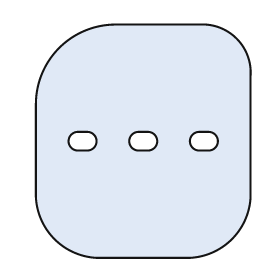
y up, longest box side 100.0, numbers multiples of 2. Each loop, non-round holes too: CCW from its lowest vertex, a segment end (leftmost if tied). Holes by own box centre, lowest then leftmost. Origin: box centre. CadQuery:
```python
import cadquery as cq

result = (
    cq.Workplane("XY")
    .moveTo(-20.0, -50.0)
    .lineTo(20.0, -50.0)
    .threePointArc((38.0, -42.0), (46.0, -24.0))
    .lineTo(46.0, 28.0)
    .threePointArc((40.0, 44.0), (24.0, 50.0))
    .lineTo(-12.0, 50.0)
    .threePointArc((-36.0, 40.0), (-46.0, 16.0))
    .lineTo(-46.0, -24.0)
    .threePointArc((-38.0, -42.0), (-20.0, -50.0))
    .close()
    .moveTo(-28.0, -4.0)
    .lineTo(-24.0, -4.0)
    .threePointArc((-20.0, 0.0), (-24.0, 4.0))
    .lineTo(-28.0, 4.0)
    .threePointArc((-32.0, 0.0), (-28.0, -4.0))
    .close()
    .moveTo(-2.0, -4.0)
    .lineTo(2.0, -4.0)
    .threePointArc((6.0, 0.0), (2.0, 4.0))
    .lineTo(-2.0, 4.0)
    .threePointArc((-6.0, 0.0), (-2.0, -4.0))
    .close()
    .moveTo(24.0, -4.0)
    .lineTo(28.0, -4.0)
    .threePointArc((32.0, 0.0), (28.0, 4.0))
    .lineTo(24.0, 4.0)
    .threePointArc((20.0, 0.0), (24.0, -4.0))
    .close()
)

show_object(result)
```